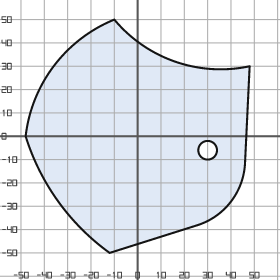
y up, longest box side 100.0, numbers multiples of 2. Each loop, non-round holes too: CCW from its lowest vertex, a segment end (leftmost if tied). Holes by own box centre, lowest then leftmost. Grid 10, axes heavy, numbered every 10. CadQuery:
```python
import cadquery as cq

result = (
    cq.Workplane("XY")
    .moveTo(-12.0, -50.0)
    .lineTo(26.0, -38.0)
    .threePointArc((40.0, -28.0), (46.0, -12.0))
    .lineTo(48.0, 30.0)
    .threePointArc((16.0, 32.0), (-10.0, 50.0))
    .threePointArc((-36.0, 30.0), (-48.0, 0.0))
    .threePointArc((-34.0, -28.0), (-12.0, -50.0))
    .close()
    .moveTo(30.0, -6.0)
    .circle(4.0)
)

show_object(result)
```